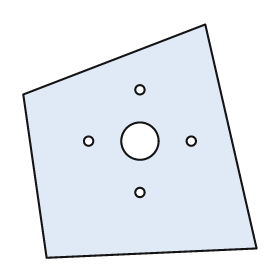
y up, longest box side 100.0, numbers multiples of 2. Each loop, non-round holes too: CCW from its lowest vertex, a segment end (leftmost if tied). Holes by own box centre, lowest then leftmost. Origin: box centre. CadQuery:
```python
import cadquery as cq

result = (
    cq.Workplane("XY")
    .moveTo(-40.0, -50.0)
    .lineTo(50.0, -46.0)
    .lineTo(28.0, 50.0)
    .lineTo(-50.0, 20.0)
    .close()
    .moveTo(0.0, -22.0)
    .circle(2.0)
    .moveTo(-22.0, 0.0)
    .circle(2.0)
    .moveTo(0.0, 0.0)
    .circle(8.0)
    .moveTo(22.0, 0.0)
    .circle(2.0)
    .moveTo(0.0, 22.0)
    .circle(2.0)
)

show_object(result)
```